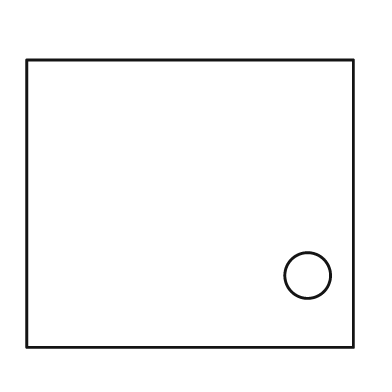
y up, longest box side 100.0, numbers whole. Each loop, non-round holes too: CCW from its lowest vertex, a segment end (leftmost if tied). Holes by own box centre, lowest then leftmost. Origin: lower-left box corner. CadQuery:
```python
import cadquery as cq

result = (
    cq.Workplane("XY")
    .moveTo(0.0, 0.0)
    .lineTo(100.0, 0.0)
    .lineTo(100.0, 88.0)
    .lineTo(0.0, 88.0)
    .close()
    .moveTo(86.0, 22.0)
    .circle(7.0)
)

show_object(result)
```